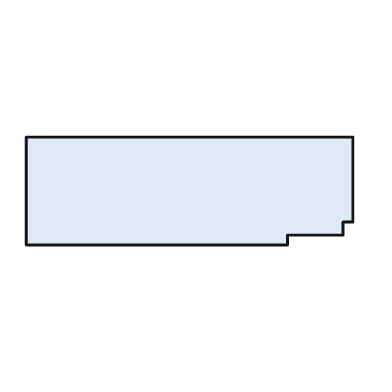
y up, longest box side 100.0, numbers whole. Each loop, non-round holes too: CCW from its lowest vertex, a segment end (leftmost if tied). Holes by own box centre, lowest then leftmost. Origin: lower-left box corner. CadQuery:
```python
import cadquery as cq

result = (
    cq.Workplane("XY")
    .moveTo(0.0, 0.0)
    .lineTo(80.0, 0.0)
    .lineTo(80.0, 3.0)
    .lineTo(97.0, 3.0)
    .lineTo(97.0, 7.0)
    .lineTo(100.0, 7.0)
    .lineTo(100.0, 33.0)
    .lineTo(0.0, 33.0)
    .close()
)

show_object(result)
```